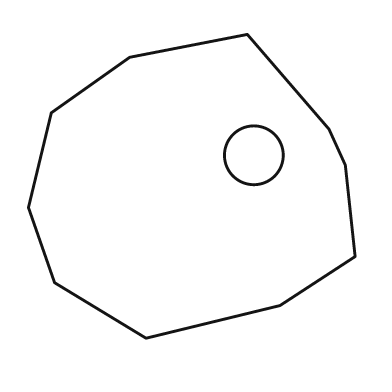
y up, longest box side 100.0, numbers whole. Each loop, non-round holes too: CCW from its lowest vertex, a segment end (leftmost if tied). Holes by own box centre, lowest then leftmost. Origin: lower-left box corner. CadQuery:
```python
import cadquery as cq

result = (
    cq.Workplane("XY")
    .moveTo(36.0, 0.0)
    .lineTo(77.0, 10.0)
    .lineTo(100.0, 25.0)
    .lineTo(97.0, 53.0)
    .lineTo(92.0, 64.0)
    .lineTo(67.0, 93.0)
    .lineTo(31.0, 86.0)
    .lineTo(7.0, 69.0)
    .lineTo(0.0, 40.0)
    .lineTo(8.0, 17.0)
    .close()
    .moveTo(69.0, 56.0)
    .circle(9.0)
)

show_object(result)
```